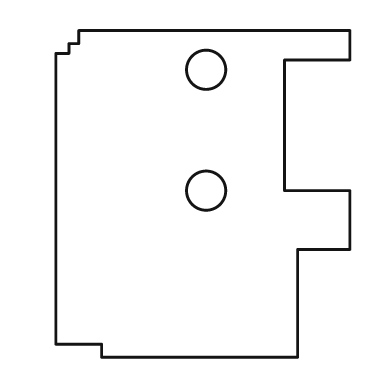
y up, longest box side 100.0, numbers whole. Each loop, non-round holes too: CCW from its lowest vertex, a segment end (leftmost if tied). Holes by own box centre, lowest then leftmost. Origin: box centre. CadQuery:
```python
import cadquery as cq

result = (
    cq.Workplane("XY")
    .moveTo(-31.0, -50.0)
    .lineTo(29.0, -50.0)
    .lineTo(29.0, -17.0)
    .lineTo(45.0, -17.0)
    .lineTo(45.0, 1.0)
    .lineTo(25.0, 1.0)
    .lineTo(25.0, 41.0)
    .lineTo(45.0, 41.0)
    .lineTo(45.0, 50.0)
    .lineTo(-38.0, 50.0)
    .lineTo(-38.0, 46.0)
    .lineTo(-41.0, 46.0)
    .lineTo(-41.0, 43.0)
    .lineTo(-45.0, 43.0)
    .lineTo(-45.0, -46.0)
    .lineTo(-31.0, -46.0)
    .close()
    .moveTo(1.0, 1.0)
    .circle(6.0)
    .moveTo(1.0, 38.0)
    .circle(6.0)
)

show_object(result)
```